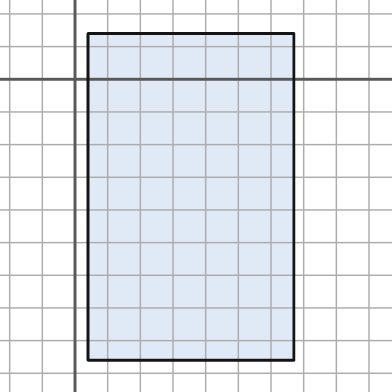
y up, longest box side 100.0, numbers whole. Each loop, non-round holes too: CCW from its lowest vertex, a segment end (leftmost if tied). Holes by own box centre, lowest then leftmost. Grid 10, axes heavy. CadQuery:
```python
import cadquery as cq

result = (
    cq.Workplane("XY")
    .moveTo(4.0, -86.0)
    .lineTo(67.0, -86.0)
    .lineTo(67.0, 14.0)
    .lineTo(4.0, 14.0)
    .close()
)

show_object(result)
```